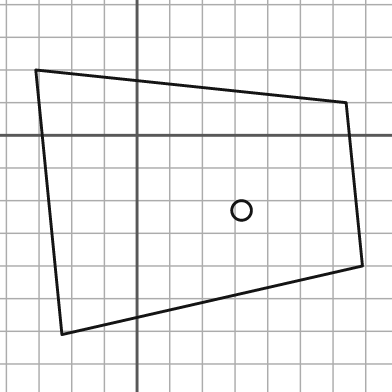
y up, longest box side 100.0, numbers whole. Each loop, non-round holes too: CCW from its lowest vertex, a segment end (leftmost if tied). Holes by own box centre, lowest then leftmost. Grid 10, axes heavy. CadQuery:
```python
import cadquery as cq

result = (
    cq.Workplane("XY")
    .moveTo(-23.0, -61.0)
    .lineTo(69.0, -40.0)
    .lineTo(64.0, 10.0)
    .lineTo(-31.0, 20.0)
    .close()
    .moveTo(32.0, -23.0)
    .circle(3.0)
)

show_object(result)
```